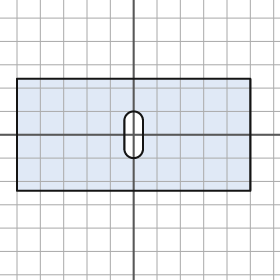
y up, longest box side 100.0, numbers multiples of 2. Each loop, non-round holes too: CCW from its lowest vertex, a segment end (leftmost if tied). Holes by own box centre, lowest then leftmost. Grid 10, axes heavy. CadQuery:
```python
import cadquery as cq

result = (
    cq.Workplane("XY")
    .moveTo(-50.0, -24.0)
    .lineTo(50.0, -24.0)
    .lineTo(50.0, 24.0)
    .lineTo(-50.0, 24.0)
    .close()
    .moveTo(-4.0, -6.0)
    .threePointArc((0.0, -10.0), (4.0, -6.0))
    .lineTo(4.0, 6.0)
    .threePointArc((0.0, 10.0), (-4.0, 6.0))
    .close()
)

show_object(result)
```